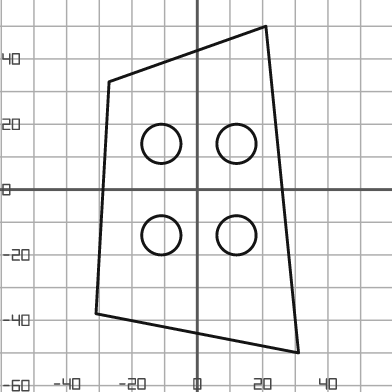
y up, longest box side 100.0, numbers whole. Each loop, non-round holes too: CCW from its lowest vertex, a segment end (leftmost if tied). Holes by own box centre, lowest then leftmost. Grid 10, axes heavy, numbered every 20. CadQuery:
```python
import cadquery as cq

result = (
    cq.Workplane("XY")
    .moveTo(31.0, -50.0)
    .lineTo(21.0, 50.0)
    .lineTo(-27.0, 33.0)
    .lineTo(-31.0, -38.0)
    .close()
    .moveTo(-11.0, -14.0)
    .circle(6.0)
    .moveTo(12.0, -14.0)
    .circle(6.0)
    .moveTo(-11.0, 14.0)
    .circle(6.0)
    .moveTo(12.0, 14.0)
    .circle(6.0)
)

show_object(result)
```